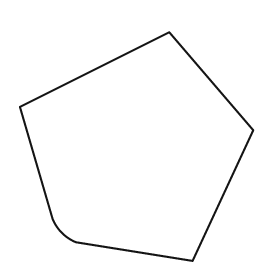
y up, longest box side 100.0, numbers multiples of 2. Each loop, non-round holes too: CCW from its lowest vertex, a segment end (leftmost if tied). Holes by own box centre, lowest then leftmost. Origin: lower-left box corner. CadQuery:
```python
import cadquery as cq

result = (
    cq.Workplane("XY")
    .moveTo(74.0, 0.0)
    .lineTo(100.0, 56.0)
    .lineTo(64.0, 98.0)
    .lineTo(0.0, 66.0)
    .lineTo(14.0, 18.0)
    .threePointArc((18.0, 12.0), (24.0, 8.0))
    .close()
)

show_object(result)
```